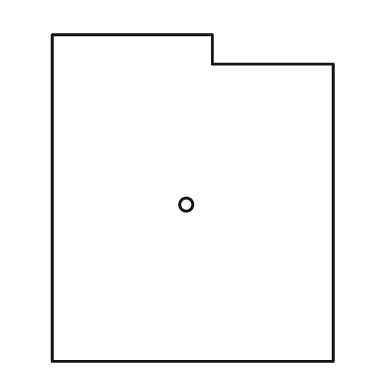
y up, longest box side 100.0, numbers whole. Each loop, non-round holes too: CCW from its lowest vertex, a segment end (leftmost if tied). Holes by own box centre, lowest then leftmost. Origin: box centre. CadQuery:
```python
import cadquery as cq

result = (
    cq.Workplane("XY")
    .moveTo(-43.0, -50.0)
    .lineTo(43.0, -50.0)
    .lineTo(43.0, 41.0)
    .lineTo(6.0, 41.0)
    .lineTo(6.0, 50.0)
    .lineTo(-43.0, 50.0)
    .close()
    .moveTo(-2.0, -2.0)
    .circle(2.0)
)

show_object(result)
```